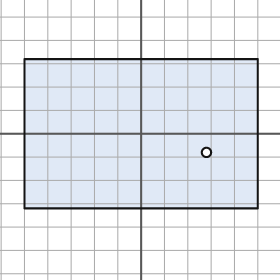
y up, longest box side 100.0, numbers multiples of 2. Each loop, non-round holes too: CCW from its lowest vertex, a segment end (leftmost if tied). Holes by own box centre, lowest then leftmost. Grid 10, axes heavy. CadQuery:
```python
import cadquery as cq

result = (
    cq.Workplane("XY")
    .moveTo(-50.0, -32.0)
    .lineTo(50.0, -32.0)
    .lineTo(50.0, 32.0)
    .lineTo(-50.0, 32.0)
    .close()
    .moveTo(28.0, -8.0)
    .circle(2.0)
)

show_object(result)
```